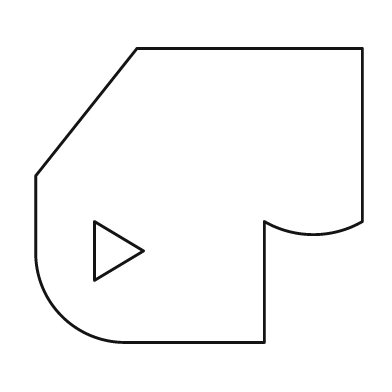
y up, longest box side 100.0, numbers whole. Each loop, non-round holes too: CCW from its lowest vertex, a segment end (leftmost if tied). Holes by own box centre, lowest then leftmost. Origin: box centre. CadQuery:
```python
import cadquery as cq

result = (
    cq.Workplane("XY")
    .moveTo(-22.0, -45.0)
    .lineTo(20.0, -45.0)
    .lineTo(20.0, -8.0)
    .threePointArc((35.0, -12.0), (50.0, -8.0))
    .lineTo(50.0, 45.0)
    .lineTo(-19.0, 45.0)
    .lineTo(-50.0, 6.0)
    .lineTo(-50.0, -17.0)
    .threePointArc((-42.0, -37.0), (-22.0, -45.0))
    .close()
    .moveTo(-32.0, -26.0)
    .lineTo(-17.0, -17.0)
    .lineTo(-32.0, -8.0)
    .close()
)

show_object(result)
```